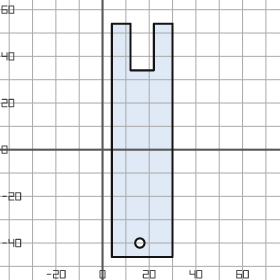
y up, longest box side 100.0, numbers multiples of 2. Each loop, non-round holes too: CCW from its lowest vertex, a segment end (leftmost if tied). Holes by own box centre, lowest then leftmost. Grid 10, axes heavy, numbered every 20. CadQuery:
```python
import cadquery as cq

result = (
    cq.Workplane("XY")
    .moveTo(4.0, -46.0)
    .lineTo(30.0, -46.0)
    .lineTo(30.0, 54.0)
    .lineTo(22.0, 54.0)
    .lineTo(22.0, 34.0)
    .lineTo(12.0, 34.0)
    .lineTo(12.0, 54.0)
    .lineTo(4.0, 54.0)
    .close()
    .moveTo(16.0, -40.0)
    .circle(2.0)
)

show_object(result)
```